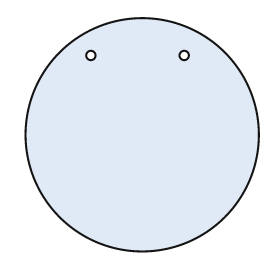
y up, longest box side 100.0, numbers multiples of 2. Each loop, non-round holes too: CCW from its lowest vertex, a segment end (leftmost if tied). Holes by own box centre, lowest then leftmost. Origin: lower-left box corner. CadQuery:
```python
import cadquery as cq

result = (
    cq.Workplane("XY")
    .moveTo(50.0, 50.0)
    .circle(50.0)
    .moveTo(28.0, 84.0)
    .circle(2.0)
    .moveTo(68.0, 84.0)
    .circle(2.0)
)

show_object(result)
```